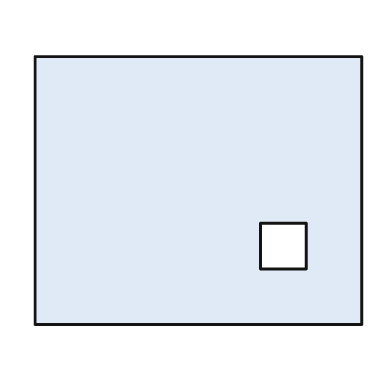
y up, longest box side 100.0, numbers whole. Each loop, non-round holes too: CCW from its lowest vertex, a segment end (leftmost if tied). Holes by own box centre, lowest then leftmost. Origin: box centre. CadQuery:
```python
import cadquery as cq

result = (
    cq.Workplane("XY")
    .moveTo(-50.0, -41.0)
    .lineTo(50.0, -41.0)
    .lineTo(50.0, 41.0)
    .lineTo(-50.0, 41.0)
    .close()
    .moveTo(19.0, -24.0)
    .lineTo(33.0, -24.0)
    .lineTo(33.0, -10.0)
    .lineTo(19.0, -10.0)
    .close()
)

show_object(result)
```